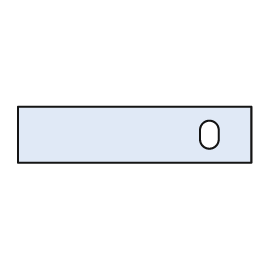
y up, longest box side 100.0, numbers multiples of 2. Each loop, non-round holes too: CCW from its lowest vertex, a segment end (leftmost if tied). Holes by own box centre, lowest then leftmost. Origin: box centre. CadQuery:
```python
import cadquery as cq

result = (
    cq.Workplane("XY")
    .moveTo(-50.0, -12.0)
    .lineTo(50.0, -12.0)
    .lineTo(50.0, 12.0)
    .lineTo(-50.0, 12.0)
    .close()
    .moveTo(28.0, -2.0)
    .threePointArc((32.0, -6.0), (36.0, -2.0))
    .lineTo(36.0, 2.0)
    .threePointArc((32.0, 6.0), (28.0, 2.0))
    .close()
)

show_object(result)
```